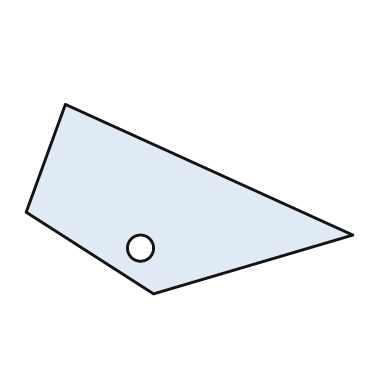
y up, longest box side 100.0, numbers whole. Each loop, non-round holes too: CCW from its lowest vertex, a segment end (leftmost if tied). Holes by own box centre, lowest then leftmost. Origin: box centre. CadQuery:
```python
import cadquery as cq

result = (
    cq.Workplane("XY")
    .moveTo(-11.0, -29.0)
    .lineTo(50.0, -11.0)
    .lineTo(-38.0, 29.0)
    .lineTo(-50.0, -4.0)
    .close()
    .moveTo(-15.0, -15.0)
    .circle(4.0)
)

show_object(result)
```